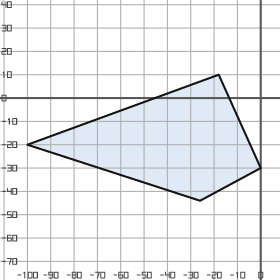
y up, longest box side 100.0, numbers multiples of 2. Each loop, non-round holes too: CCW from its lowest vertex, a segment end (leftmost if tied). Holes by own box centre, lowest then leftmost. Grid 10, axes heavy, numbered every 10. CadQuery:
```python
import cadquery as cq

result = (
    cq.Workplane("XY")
    .moveTo(-26.0, -44.0)
    .lineTo(0.0, -30.0)
    .lineTo(-18.0, 10.0)
    .lineTo(-100.0, -20.0)
    .close()
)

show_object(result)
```